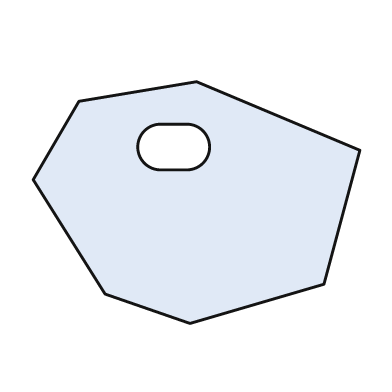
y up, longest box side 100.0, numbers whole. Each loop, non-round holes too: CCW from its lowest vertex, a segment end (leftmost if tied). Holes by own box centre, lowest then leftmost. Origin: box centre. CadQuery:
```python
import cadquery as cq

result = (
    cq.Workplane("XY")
    .moveTo(-2.0, -37.0)
    .lineTo(39.0, -25.0)
    .lineTo(50.0, 16.0)
    .lineTo(0.0, 37.0)
    .lineTo(-36.0, 31.0)
    .lineTo(-50.0, 7.0)
    .lineTo(-28.0, -28.0)
    .close()
    .moveTo(-11.0, 10.0)
    .lineTo(-3.0, 10.0)
    .threePointArc((4.0, 17.0), (-3.0, 24.0))
    .lineTo(-11.0, 24.0)
    .threePointArc((-18.0, 17.0), (-11.0, 10.0))
    .close()
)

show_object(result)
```